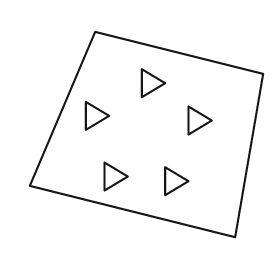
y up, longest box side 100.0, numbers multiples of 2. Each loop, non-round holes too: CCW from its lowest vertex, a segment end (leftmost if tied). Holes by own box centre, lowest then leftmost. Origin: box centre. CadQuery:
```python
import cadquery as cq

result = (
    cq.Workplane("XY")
    .moveTo(38.0, -44.0)
    .lineTo(50.0, 26.0)
    .lineTo(-22.0, 44.0)
    .lineTo(-50.0, -22.0)
    .close()
    .moveTo(8.0, -26.0)
    .lineTo(18.0, -20.0)
    .lineTo(8.0, -14.0)
    .close()
    .moveTo(-18.0, -24.0)
    .lineTo(-8.0, -18.0)
    .lineTo(-18.0, -12.0)
    .close()
    .moveTo(18.0, 0.0)
    .lineTo(28.0, 6.0)
    .lineTo(18.0, 12.0)
    .close()
    .moveTo(-26.0, 2.0)
    .lineTo(-16.0, 8.0)
    .lineTo(-26.0, 14.0)
    .close()
    .moveTo(-2.0, 16.0)
    .lineTo(8.0, 22.0)
    .lineTo(-2.0, 28.0)
    .close()
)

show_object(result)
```